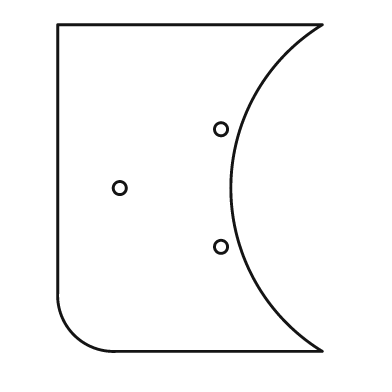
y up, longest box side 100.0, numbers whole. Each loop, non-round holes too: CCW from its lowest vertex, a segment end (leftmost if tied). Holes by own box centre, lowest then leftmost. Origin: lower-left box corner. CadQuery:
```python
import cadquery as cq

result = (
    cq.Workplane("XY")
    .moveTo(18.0, 0.0)
    .lineTo(81.0, 0.0)
    .threePointArc((53.0, 50.0), (81.0, 100.0))
    .lineTo(0.0, 100.0)
    .lineTo(0.0, 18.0)
    .threePointArc((5.0, 5.0), (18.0, 0.0))
    .close()
    .moveTo(50.0, 32.0)
    .circle(2.0)
    .moveTo(19.0, 50.0)
    .circle(2.0)
    .moveTo(50.0, 68.0)
    .circle(2.0)
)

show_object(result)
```